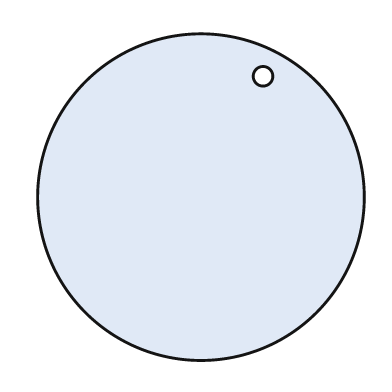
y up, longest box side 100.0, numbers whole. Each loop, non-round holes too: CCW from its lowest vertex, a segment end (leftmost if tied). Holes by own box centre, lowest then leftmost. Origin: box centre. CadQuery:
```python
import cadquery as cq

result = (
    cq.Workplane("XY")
    .moveTo(0.0, 0.0)
    .circle(50.0)
    .moveTo(19.0, 37.0)
    .circle(3.0)
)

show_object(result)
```